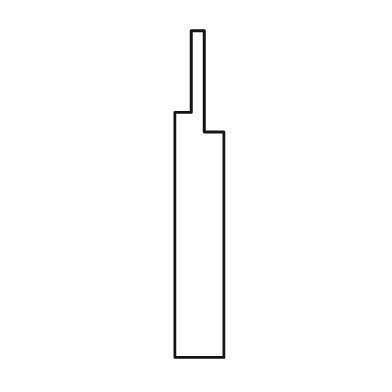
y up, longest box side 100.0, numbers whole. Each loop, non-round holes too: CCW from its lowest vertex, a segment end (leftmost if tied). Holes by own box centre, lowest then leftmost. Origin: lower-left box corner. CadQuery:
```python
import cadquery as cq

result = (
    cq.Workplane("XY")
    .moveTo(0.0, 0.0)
    .lineTo(15.0, 0.0)
    .lineTo(15.0, 69.0)
    .lineTo(9.0, 69.0)
    .lineTo(9.0, 100.0)
    .lineTo(5.0, 100.0)
    .lineTo(5.0, 75.0)
    .lineTo(0.0, 75.0)
    .close()
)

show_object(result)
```